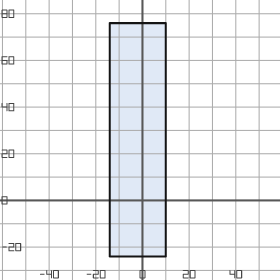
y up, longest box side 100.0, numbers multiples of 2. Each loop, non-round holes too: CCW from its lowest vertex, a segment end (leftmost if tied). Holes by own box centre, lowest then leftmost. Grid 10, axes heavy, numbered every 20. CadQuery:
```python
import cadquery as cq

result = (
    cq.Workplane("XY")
    .moveTo(-14.0, -24.0)
    .lineTo(10.0, -24.0)
    .lineTo(10.0, 76.0)
    .lineTo(-14.0, 76.0)
    .close()
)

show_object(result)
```